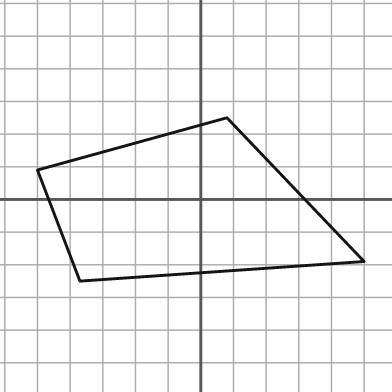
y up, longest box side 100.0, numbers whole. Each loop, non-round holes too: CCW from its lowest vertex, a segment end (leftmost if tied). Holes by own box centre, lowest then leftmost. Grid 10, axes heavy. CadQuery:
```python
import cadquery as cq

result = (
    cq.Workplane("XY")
    .moveTo(-37.0, -25.0)
    .lineTo(50.0, -19.0)
    .lineTo(8.0, 25.0)
    .lineTo(-50.0, 9.0)
    .close()
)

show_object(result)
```